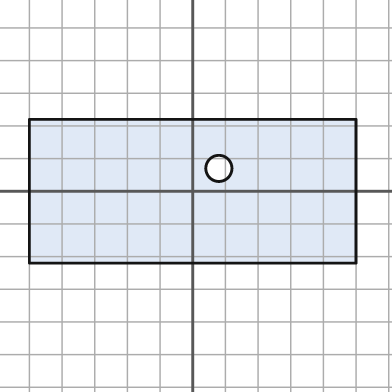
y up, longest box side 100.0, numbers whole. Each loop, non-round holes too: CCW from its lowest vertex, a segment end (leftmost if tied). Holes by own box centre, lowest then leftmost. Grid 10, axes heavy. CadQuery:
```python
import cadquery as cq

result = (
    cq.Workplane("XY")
    .moveTo(-50.0, -22.0)
    .lineTo(50.0, -22.0)
    .lineTo(50.0, 22.0)
    .lineTo(-50.0, 22.0)
    .close()
    .moveTo(8.0, 7.0)
    .circle(4.0)
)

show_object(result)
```